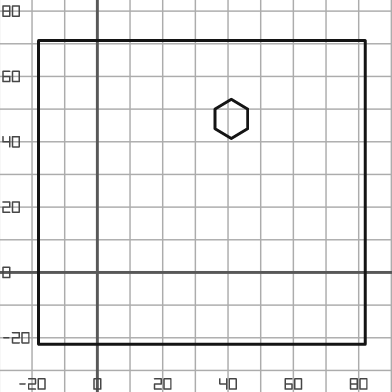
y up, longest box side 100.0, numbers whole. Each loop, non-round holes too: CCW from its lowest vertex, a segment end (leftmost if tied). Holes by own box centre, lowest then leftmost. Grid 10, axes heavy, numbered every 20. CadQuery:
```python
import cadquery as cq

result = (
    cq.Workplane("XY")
    .moveTo(-18.0, -22.0)
    .lineTo(82.0, -22.0)
    .lineTo(82.0, 71.0)
    .lineTo(-18.0, 71.0)
    .close()
    .moveTo(41.0, 41.0)
    .lineTo(46.0, 44.0)
    .lineTo(46.0, 50.0)
    .lineTo(41.0, 53.0)
    .lineTo(36.0, 50.0)
    .lineTo(36.0, 44.0)
    .close()
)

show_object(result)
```